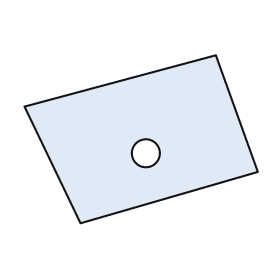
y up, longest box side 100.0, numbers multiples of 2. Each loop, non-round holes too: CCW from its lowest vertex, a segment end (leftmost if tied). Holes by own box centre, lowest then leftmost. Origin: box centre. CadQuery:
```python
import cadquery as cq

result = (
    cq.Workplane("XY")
    .moveTo(-26.0, -36.0)
    .lineTo(50.0, -14.0)
    .lineTo(32.0, 36.0)
    .lineTo(-50.0, 14.0)
    .close()
    .moveTo(2.0, -6.0)
    .circle(6.0)
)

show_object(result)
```